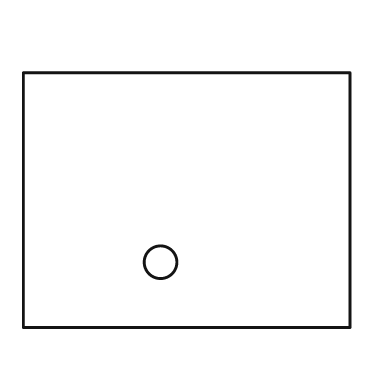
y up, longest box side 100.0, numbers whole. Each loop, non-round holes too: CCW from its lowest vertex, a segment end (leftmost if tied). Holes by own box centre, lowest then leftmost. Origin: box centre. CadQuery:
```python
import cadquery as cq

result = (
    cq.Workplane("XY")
    .moveTo(-50.0, -39.0)
    .lineTo(50.0, -39.0)
    .lineTo(50.0, 39.0)
    .lineTo(-50.0, 39.0)
    .close()
    .moveTo(-8.0, -19.0)
    .circle(5.0)
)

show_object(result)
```